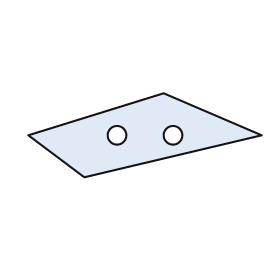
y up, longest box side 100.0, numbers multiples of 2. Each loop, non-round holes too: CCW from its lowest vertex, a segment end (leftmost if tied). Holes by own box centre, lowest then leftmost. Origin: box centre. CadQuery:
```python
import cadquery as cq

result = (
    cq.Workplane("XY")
    .moveTo(-26.0, -18.0)
    .lineTo(50.0, 0.0)
    .lineTo(8.0, 18.0)
    .lineTo(-50.0, 0.0)
    .close()
    .moveTo(-12.0, 0.0)
    .circle(4.0)
    .moveTo(12.0, 0.0)
    .circle(4.0)
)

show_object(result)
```